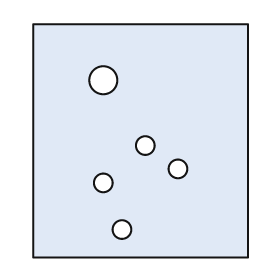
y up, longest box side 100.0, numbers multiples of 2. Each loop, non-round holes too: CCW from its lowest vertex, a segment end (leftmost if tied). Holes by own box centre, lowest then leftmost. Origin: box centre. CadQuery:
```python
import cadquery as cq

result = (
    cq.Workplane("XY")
    .moveTo(-46.0, -50.0)
    .lineTo(46.0, -50.0)
    .lineTo(46.0, 50.0)
    .lineTo(-46.0, 50.0)
    .close()
    .moveTo(-8.0, -38.0)
    .circle(4.0)
    .moveTo(-16.0, -18.0)
    .circle(4.0)
    .moveTo(16.0, -12.0)
    .circle(4.0)
    .moveTo(2.0, -2.0)
    .circle(4.0)
    .moveTo(-16.0, 26.0)
    .circle(6.0)
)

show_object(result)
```